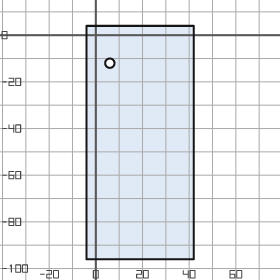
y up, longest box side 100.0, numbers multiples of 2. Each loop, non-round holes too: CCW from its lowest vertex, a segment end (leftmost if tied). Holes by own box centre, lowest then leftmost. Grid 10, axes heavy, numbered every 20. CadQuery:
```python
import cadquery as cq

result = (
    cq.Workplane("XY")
    .moveTo(-4.0, -96.0)
    .lineTo(42.0, -96.0)
    .lineTo(42.0, 4.0)
    .lineTo(-4.0, 4.0)
    .close()
    .moveTo(6.0, -12.0)
    .circle(2.0)
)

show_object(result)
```